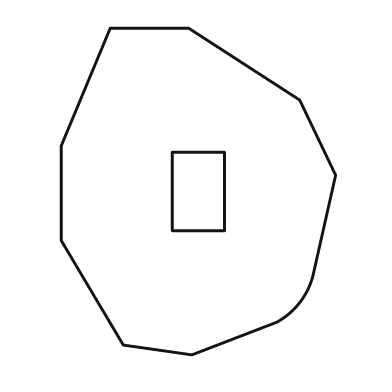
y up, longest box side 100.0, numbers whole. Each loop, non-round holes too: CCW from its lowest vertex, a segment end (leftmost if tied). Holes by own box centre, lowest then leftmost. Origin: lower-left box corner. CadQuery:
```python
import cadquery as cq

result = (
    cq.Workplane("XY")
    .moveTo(40.0, 0.0)
    .lineTo(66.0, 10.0)
    .threePointArc((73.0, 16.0), (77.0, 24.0))
    .lineTo(84.0, 55.0)
    .lineTo(73.0, 78.0)
    .lineTo(39.0, 100.0)
    .lineTo(15.0, 100.0)
    .lineTo(0.0, 64.0)
    .lineTo(0.0, 35.0)
    .lineTo(19.0, 3.0)
    .close()
    .moveTo(34.0, 38.0)
    .lineTo(50.0, 38.0)
    .lineTo(50.0, 62.0)
    .lineTo(34.0, 62.0)
    .close()
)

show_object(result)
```